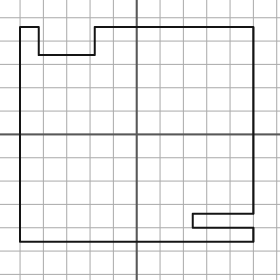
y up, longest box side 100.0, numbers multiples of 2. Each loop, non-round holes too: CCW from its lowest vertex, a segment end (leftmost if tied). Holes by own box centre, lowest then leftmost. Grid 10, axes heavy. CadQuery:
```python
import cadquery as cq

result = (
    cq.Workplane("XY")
    .moveTo(-50.0, -46.0)
    .lineTo(50.0, -46.0)
    .lineTo(50.0, -40.0)
    .lineTo(24.0, -40.0)
    .lineTo(24.0, -34.0)
    .lineTo(50.0, -34.0)
    .lineTo(50.0, 46.0)
    .lineTo(-18.0, 46.0)
    .lineTo(-18.0, 34.0)
    .lineTo(-42.0, 34.0)
    .lineTo(-42.0, 46.0)
    .lineTo(-50.0, 46.0)
    .close()
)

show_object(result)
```